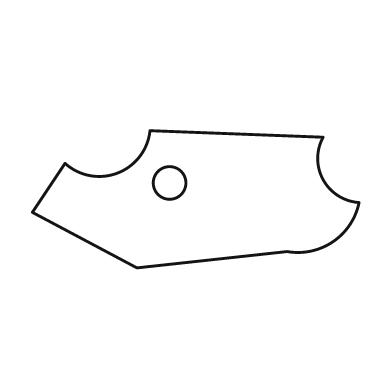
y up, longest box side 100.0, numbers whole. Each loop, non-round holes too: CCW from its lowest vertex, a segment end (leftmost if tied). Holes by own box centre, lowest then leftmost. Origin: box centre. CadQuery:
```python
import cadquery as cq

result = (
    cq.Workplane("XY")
    .moveTo(-18.0, -21.0)
    .lineTo(28.0, -16.0)
    .threePointArc((42.0, -13.0), (50.0, -1.0))
    .threePointArc((39.0, 6.0), (39.0, 19.0))
    .lineTo(-14.0, 21.0)
    .threePointArc((-24.0, 8.0), (-40.0, 11.0))
    .lineTo(-50.0, -4.0)
    .close()
    .moveTo(-8.0, 5.0)
    .circle(5.0)
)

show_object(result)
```